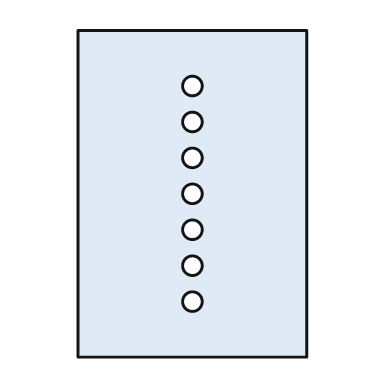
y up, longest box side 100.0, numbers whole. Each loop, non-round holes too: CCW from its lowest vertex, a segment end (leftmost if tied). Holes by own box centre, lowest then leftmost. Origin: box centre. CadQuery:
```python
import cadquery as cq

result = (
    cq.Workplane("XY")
    .moveTo(-35.0, -50.0)
    .lineTo(35.0, -50.0)
    .lineTo(35.0, 50.0)
    .lineTo(-35.0, 50.0)
    .close()
    .moveTo(0.0, -33.0)
    .circle(3.0)
    .moveTo(0.0, -22.0)
    .circle(3.0)
    .moveTo(0.0, -11.0)
    .circle(3.0)
    .moveTo(0.0, 0.0)
    .circle(3.0)
    .moveTo(0.0, 11.0)
    .circle(3.0)
    .moveTo(0.0, 22.0)
    .circle(3.0)
    .moveTo(0.0, 33.0)
    .circle(3.0)
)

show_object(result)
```